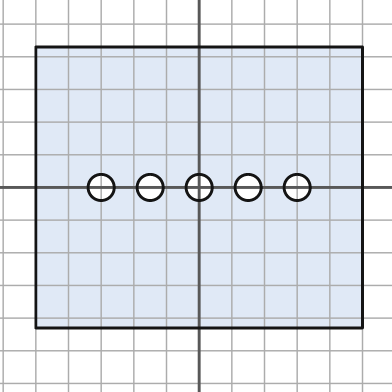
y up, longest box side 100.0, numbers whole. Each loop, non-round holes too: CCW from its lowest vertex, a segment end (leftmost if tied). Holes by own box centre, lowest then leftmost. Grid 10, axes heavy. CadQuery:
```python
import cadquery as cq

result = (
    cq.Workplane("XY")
    .moveTo(-50.0, -43.0)
    .lineTo(50.0, -43.0)
    .lineTo(50.0, 43.0)
    .lineTo(-50.0, 43.0)
    .close()
    .moveTo(-30.0, 0.0)
    .circle(4.0)
    .moveTo(-15.0, 0.0)
    .circle(4.0)
    .moveTo(0.0, 0.0)
    .circle(4.0)
    .moveTo(15.0, 0.0)
    .circle(4.0)
    .moveTo(30.0, 0.0)
    .circle(4.0)
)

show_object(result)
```